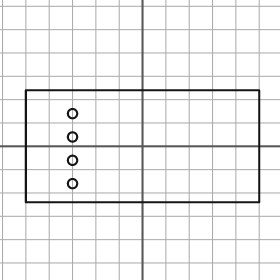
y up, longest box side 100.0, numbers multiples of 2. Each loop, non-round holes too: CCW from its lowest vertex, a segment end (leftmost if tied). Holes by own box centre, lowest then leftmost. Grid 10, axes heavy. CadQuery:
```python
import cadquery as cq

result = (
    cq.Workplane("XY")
    .moveTo(-50.0, -24.0)
    .lineTo(50.0, -24.0)
    .lineTo(50.0, 24.0)
    .lineTo(-50.0, 24.0)
    .close()
    .moveTo(-30.0, -16.0)
    .circle(2.0)
    .moveTo(-30.0, -6.0)
    .circle(2.0)
    .moveTo(-30.0, 4.0)
    .circle(2.0)
    .moveTo(-30.0, 14.0)
    .circle(2.0)
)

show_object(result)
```